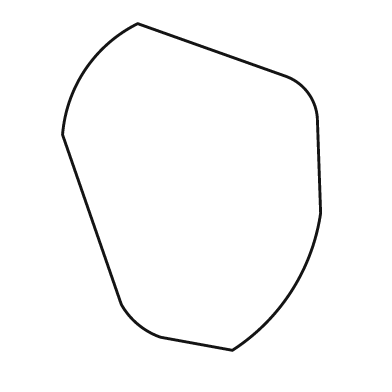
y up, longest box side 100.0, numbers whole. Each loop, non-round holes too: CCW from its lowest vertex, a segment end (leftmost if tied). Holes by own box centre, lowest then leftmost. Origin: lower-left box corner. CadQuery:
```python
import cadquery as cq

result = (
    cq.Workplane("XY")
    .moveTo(52.0, 0.0)
    .threePointArc((70.0, 18.0), (79.0, 42.0))
    .lineTo(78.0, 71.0)
    .threePointArc((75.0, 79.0), (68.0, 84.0))
    .lineTo(23.0, 100.0)
    .threePointArc((7.0, 86.0), (0.0, 66.0))
    .lineTo(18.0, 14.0)
    .threePointArc((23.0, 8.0), (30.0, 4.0))
    .close()
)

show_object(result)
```